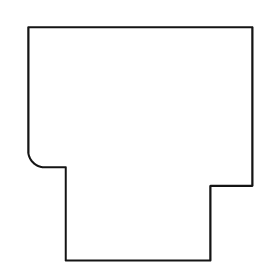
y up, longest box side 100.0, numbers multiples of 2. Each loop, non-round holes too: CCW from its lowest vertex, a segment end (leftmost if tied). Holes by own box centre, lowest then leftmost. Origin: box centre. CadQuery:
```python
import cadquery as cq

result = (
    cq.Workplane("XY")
    .moveTo(-32.0, -50.0)
    .lineTo(30.0, -50.0)
    .lineTo(30.0, -18.0)
    .lineTo(48.0, -18.0)
    .lineTo(48.0, 50.0)
    .lineTo(-48.0, 50.0)
    .lineTo(-48.0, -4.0)
    .threePointArc((-46.0, -8.0), (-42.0, -10.0))
    .lineTo(-32.0, -10.0)
    .close()
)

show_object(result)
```